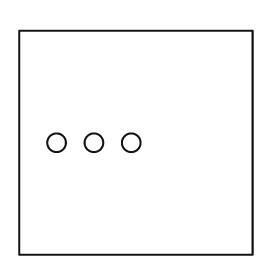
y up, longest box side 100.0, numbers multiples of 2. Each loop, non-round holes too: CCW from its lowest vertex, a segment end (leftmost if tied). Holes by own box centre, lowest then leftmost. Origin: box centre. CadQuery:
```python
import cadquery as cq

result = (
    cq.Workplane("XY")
    .moveTo(-50.0, -48.0)
    .lineTo(50.0, -48.0)
    .lineTo(50.0, 48.0)
    .lineTo(-50.0, 48.0)
    .close()
    .moveTo(-34.0, 0.0)
    .circle(4.0)
    .moveTo(-18.0, 0.0)
    .circle(4.0)
    .moveTo(-2.0, 0.0)
    .circle(4.0)
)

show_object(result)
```